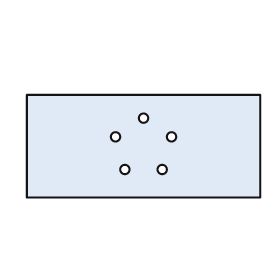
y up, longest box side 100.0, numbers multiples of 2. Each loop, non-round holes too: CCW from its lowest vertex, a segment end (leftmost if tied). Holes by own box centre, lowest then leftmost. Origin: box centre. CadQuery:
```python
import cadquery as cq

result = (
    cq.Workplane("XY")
    .moveTo(-50.0, -22.0)
    .lineTo(50.0, -22.0)
    .lineTo(50.0, 22.0)
    .lineTo(-50.0, 22.0)
    .close()
    .moveTo(-8.0, -10.0)
    .circle(2.0)
    .moveTo(8.0, -10.0)
    .circle(2.0)
    .moveTo(-12.0, 4.0)
    .circle(2.0)
    .moveTo(12.0, 4.0)
    .circle(2.0)
    .moveTo(0.0, 12.0)
    .circle(2.0)
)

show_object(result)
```